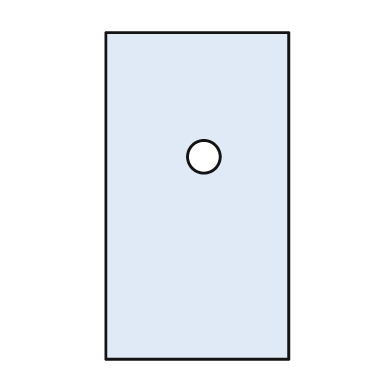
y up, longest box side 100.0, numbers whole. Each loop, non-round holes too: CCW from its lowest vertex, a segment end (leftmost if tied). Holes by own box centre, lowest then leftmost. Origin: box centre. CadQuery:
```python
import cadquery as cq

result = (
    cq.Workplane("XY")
    .moveTo(-28.0, -50.0)
    .lineTo(28.0, -50.0)
    .lineTo(28.0, 50.0)
    .lineTo(-28.0, 50.0)
    .close()
    .moveTo(2.0, 12.0)
    .circle(5.0)
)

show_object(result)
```